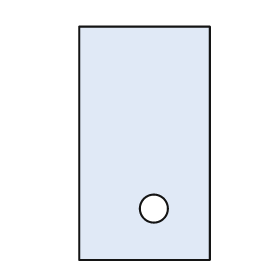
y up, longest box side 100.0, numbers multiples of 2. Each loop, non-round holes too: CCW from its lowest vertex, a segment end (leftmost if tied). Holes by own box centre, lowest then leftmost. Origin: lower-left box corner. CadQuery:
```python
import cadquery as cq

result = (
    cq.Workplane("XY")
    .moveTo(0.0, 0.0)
    .lineTo(56.0, 0.0)
    .lineTo(56.0, 100.0)
    .lineTo(0.0, 100.0)
    .close()
    .moveTo(32.0, 22.0)
    .circle(6.0)
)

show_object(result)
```